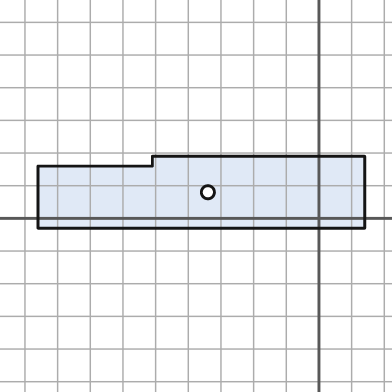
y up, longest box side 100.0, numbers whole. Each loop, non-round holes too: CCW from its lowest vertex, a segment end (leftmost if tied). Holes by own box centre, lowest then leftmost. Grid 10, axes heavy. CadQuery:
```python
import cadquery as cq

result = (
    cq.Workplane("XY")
    .moveTo(-86.0, -3.0)
    .lineTo(14.0, -3.0)
    .lineTo(14.0, 19.0)
    .lineTo(-51.0, 19.0)
    .lineTo(-51.0, 16.0)
    .lineTo(-86.0, 16.0)
    .close()
    .moveTo(-34.0, 8.0)
    .circle(2.0)
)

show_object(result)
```